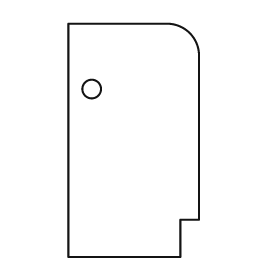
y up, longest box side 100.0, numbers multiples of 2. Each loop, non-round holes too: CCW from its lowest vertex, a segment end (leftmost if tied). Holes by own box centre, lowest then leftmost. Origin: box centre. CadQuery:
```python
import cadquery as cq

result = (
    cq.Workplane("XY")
    .moveTo(-28.0, -50.0)
    .lineTo(20.0, -50.0)
    .lineTo(20.0, -34.0)
    .lineTo(28.0, -34.0)
    .lineTo(28.0, 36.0)
    .threePointArc((24.0, 46.0), (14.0, 50.0))
    .lineTo(-28.0, 50.0)
    .close()
    .moveTo(-18.0, 22.0)
    .circle(4.0)
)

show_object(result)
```